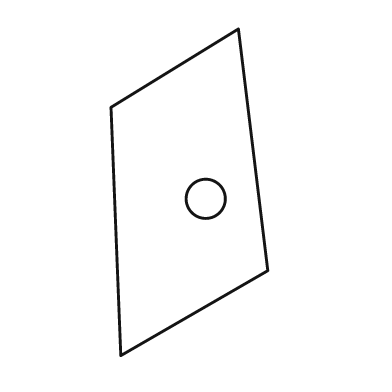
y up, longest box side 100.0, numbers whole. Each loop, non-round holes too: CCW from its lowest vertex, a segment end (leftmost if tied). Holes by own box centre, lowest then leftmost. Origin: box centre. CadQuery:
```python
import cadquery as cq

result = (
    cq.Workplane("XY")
    .moveTo(-21.0, -50.0)
    .lineTo(24.0, -24.0)
    .lineTo(15.0, 50.0)
    .lineTo(-24.0, 26.0)
    .close()
    .moveTo(5.0, -2.0)
    .circle(6.0)
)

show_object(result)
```